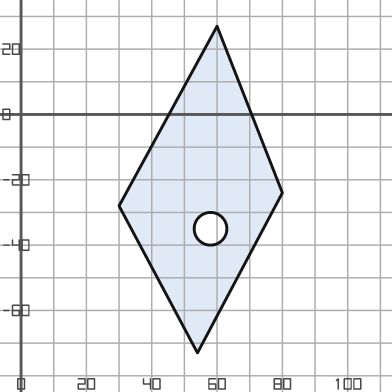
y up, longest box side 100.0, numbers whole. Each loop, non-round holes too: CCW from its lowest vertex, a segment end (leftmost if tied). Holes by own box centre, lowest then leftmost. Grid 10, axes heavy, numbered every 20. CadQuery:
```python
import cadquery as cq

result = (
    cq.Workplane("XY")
    .moveTo(54.0, -73.0)
    .lineTo(80.0, -24.0)
    .lineTo(60.0, 27.0)
    .lineTo(30.0, -28.0)
    .close()
    .moveTo(58.0, -35.0)
    .circle(5.0)
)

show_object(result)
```